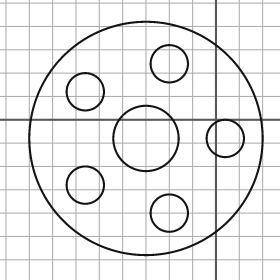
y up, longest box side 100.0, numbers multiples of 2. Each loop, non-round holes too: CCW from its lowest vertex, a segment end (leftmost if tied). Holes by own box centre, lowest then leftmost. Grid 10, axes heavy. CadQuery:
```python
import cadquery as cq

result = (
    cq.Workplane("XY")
    .moveTo(-30.0, -8.0)
    .circle(50.0)
    .moveTo(-20.0, -40.0)
    .circle(8.0)
    .moveTo(-56.0, -28.0)
    .circle(8.0)
    .moveTo(-30.0, -8.0)
    .circle(14.0)
    .moveTo(4.0, -8.0)
    .circle(8.0)
    .moveTo(-56.0, 12.0)
    .circle(8.0)
    .moveTo(-20.0, 24.0)
    .circle(8.0)
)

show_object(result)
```